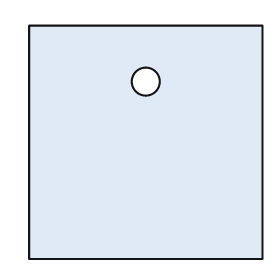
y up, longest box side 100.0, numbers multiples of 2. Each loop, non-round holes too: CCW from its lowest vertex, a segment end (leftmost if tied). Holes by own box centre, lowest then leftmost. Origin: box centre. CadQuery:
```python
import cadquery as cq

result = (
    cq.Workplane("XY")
    .moveTo(-50.0, -50.0)
    .lineTo(50.0, -50.0)
    .lineTo(50.0, 50.0)
    .lineTo(-50.0, 50.0)
    .close()
    .moveTo(0.0, 26.0)
    .circle(6.0)
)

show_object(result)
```